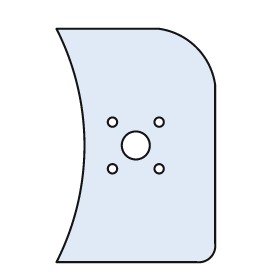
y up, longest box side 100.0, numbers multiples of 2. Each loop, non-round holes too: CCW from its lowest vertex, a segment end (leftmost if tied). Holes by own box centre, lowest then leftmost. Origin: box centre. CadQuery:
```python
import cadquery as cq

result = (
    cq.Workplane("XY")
    .moveTo(-34.0, -50.0)
    .lineTo(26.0, -50.0)
    .threePointArc((32.0, -48.0), (34.0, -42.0))
    .lineTo(34.0, 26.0)
    .threePointArc((26.0, 42.0), (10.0, 50.0))
    .lineTo(-34.0, 50.0)
    .threePointArc((-22.0, 0.0), (-34.0, -50.0))
    .close()
    .moveTo(-10.0, -10.0)
    .circle(2.0)
    .moveTo(10.0, -10.0)
    .circle(2.0)
    .moveTo(0.0, 0.0)
    .circle(6.0)
    .moveTo(-10.0, 10.0)
    .circle(2.0)
    .moveTo(10.0, 10.0)
    .circle(2.0)
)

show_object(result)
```